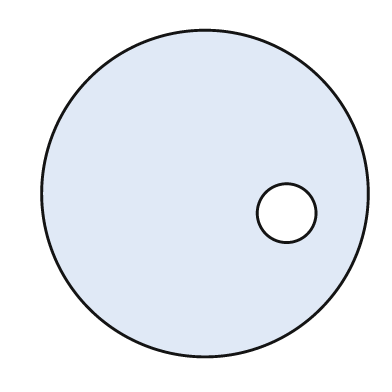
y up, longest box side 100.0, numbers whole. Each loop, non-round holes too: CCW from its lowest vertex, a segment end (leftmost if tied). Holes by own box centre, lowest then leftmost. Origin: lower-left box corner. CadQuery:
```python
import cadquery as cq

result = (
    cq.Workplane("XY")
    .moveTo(50.0, 50.0)
    .circle(50.0)
    .moveTo(75.0, 44.0)
    .circle(9.0)
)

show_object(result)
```